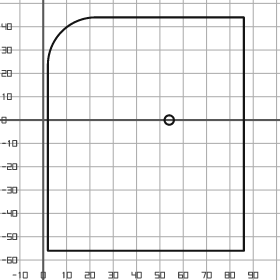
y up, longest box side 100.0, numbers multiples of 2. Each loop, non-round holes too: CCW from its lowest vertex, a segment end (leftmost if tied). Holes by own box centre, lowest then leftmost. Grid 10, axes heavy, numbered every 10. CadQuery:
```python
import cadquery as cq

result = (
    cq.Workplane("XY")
    .moveTo(2.0, -56.0)
    .lineTo(86.0, -56.0)
    .lineTo(86.0, 44.0)
    .lineTo(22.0, 44.0)
    .threePointArc((8.0, 38.0), (2.0, 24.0))
    .close()
    .moveTo(54.0, 0.0)
    .circle(2.0)
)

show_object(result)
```